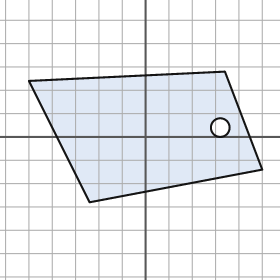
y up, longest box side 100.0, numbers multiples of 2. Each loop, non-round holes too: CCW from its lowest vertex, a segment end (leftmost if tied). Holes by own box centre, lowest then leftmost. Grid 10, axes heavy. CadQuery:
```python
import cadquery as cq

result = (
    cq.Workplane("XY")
    .moveTo(-24.0, -28.0)
    .lineTo(50.0, -14.0)
    .lineTo(34.0, 28.0)
    .lineTo(-50.0, 24.0)
    .close()
    .moveTo(32.0, 4.0)
    .circle(4.0)
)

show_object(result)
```